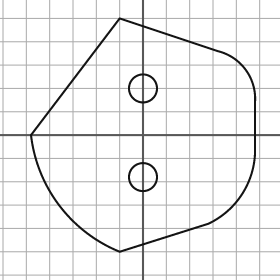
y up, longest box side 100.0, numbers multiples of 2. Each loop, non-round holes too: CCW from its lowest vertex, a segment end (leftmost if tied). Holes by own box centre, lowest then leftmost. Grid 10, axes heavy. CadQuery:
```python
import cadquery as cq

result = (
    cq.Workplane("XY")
    .moveTo(-10.0, -50.0)
    .lineTo(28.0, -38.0)
    .threePointArc((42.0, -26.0), (48.0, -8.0))
    .lineTo(48.0, 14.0)
    .threePointArc((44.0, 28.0), (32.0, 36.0))
    .lineTo(-10.0, 50.0)
    .lineTo(-48.0, 0.0)
    .threePointArc((-36.0, -30.0), (-10.0, -50.0))
    .close()
    .moveTo(0.0, -18.0)
    .circle(6.0)
    .moveTo(0.0, 20.0)
    .circle(6.0)
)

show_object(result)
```